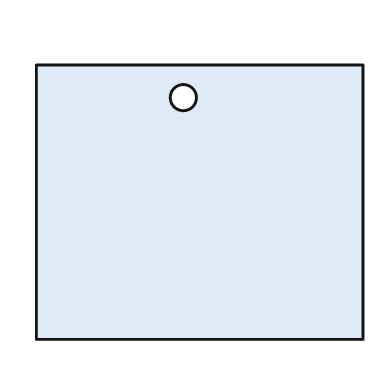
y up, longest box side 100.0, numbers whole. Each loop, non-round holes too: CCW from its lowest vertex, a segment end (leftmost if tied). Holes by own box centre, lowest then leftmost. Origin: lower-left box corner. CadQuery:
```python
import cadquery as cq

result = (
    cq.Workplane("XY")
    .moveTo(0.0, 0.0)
    .lineTo(100.0, 0.0)
    .lineTo(100.0, 84.0)
    .lineTo(0.0, 84.0)
    .close()
    .moveTo(45.0, 74.0)
    .circle(4.0)
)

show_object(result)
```